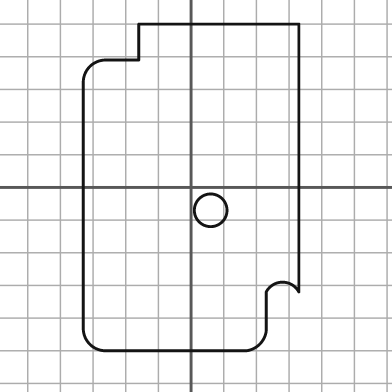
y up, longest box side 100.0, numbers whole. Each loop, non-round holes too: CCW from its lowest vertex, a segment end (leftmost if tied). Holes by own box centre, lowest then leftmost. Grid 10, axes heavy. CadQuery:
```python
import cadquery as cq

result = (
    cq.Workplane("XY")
    .moveTo(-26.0, -50.0)
    .lineTo(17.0, -50.0)
    .threePointArc((21.0, -48.0), (23.0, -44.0))
    .lineTo(23.0, -32.0)
    .threePointArc((28.0, -29.0), (33.0, -32.0))
    .lineTo(33.0, 50.0)
    .lineTo(-16.0, 50.0)
    .lineTo(-16.0, 39.0)
    .lineTo(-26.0, 39.0)
    .threePointArc((-31.0, 37.0), (-33.0, 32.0))
    .lineTo(-33.0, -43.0)
    .threePointArc((-31.0, -48.0), (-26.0, -50.0))
    .close()
    .moveTo(6.0, -7.0)
    .circle(5.0)
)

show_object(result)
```